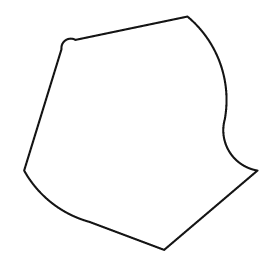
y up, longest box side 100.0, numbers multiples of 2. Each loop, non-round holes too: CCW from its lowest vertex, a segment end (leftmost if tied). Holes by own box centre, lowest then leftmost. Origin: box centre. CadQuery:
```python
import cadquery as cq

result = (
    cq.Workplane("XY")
    .moveTo(10.0, -50.0)
    .lineTo(50.0, -16.0)
    .threePointArc((38.0, -8.0), (36.0, 6.0))
    .threePointArc((34.0, 30.0), (20.0, 50.0))
    .lineTo(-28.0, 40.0)
    .threePointArc((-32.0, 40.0), (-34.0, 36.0))
    .lineTo(-50.0, -16.0)
    .threePointArc((-38.0, -30.0), (-22.0, -38.0))
    .close()
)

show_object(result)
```